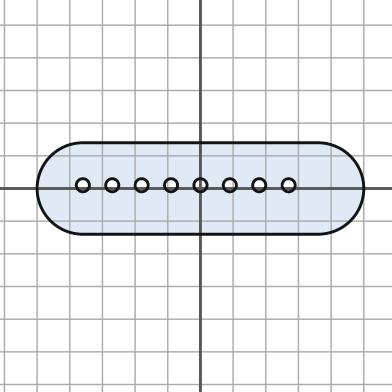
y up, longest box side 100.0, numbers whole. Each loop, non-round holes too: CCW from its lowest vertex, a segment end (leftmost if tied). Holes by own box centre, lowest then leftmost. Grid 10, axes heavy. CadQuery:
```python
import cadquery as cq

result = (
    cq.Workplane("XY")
    .moveTo(-36.0, -14.0)
    .lineTo(36.0, -14.0)
    .threePointArc((50.0, 0.0), (36.0, 14.0))
    .lineTo(-36.0, 14.0)
    .threePointArc((-50.0, 0.0), (-36.0, -14.0))
    .close()
    .moveTo(-36.0, 1.0)
    .circle(2.0)
    .moveTo(-27.0, 1.0)
    .circle(2.0)
    .moveTo(-18.0, 1.0)
    .circle(2.0)
    .moveTo(-9.0, 1.0)
    .circle(2.0)
    .moveTo(0.0, 1.0)
    .circle(2.0)
    .moveTo(9.0, 1.0)
    .circle(2.0)
    .moveTo(18.0, 1.0)
    .circle(2.0)
    .moveTo(27.0, 1.0)
    .circle(2.0)
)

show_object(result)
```